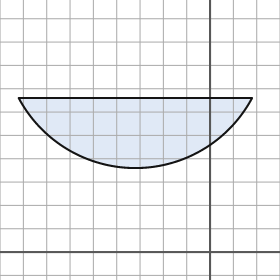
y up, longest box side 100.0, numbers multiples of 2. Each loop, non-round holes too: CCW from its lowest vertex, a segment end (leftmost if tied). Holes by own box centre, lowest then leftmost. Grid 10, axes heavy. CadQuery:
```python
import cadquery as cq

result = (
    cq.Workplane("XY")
    .moveTo(-82.0, 66.0)
    .threePointArc((-32.0, 36.0), (18.0, 66.0))
    .close()
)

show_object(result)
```